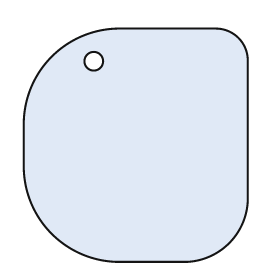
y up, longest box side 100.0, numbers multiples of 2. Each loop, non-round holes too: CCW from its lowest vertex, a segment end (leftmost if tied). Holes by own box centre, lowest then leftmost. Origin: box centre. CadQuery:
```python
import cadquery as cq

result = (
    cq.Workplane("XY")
    .moveTo(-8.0, -50.0)
    .lineTo(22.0, -50.0)
    .threePointArc((40.0, -42.0), (48.0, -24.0))
    .lineTo(48.0, 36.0)
    .threePointArc((44.0, 46.0), (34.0, 50.0))
    .lineTo(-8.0, 50.0)
    .threePointArc((-36.0, 38.0), (-48.0, 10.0))
    .lineTo(-48.0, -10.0)
    .threePointArc((-36.0, -38.0), (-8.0, -50.0))
    .close()
    .moveTo(-18.0, 36.0)
    .circle(4.0)
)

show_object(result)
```